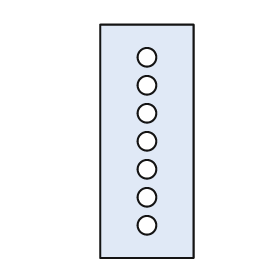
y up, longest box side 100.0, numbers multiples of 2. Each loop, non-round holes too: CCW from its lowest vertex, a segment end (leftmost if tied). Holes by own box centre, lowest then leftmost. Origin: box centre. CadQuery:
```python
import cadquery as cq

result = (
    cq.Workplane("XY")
    .moveTo(-20.0, -50.0)
    .lineTo(20.0, -50.0)
    .lineTo(20.0, 50.0)
    .lineTo(-20.0, 50.0)
    .close()
    .moveTo(0.0, -36.0)
    .circle(4.0)
    .moveTo(0.0, -24.0)
    .circle(4.0)
    .moveTo(0.0, -12.0)
    .circle(4.0)
    .moveTo(0.0, 0.0)
    .circle(4.0)
    .moveTo(0.0, 12.0)
    .circle(4.0)
    .moveTo(0.0, 24.0)
    .circle(4.0)
    .moveTo(0.0, 36.0)
    .circle(4.0)
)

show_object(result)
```